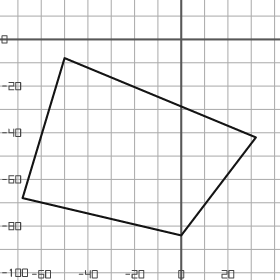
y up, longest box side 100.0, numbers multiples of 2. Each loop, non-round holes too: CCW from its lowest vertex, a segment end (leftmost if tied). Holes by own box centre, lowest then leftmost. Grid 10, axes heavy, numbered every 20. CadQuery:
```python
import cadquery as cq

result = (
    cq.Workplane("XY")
    .moveTo(0.0, -84.0)
    .lineTo(32.0, -42.0)
    .lineTo(-50.0, -8.0)
    .lineTo(-68.0, -68.0)
    .close()
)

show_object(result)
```